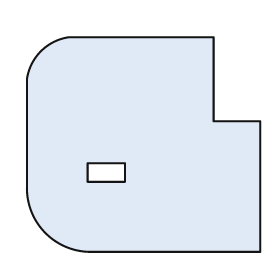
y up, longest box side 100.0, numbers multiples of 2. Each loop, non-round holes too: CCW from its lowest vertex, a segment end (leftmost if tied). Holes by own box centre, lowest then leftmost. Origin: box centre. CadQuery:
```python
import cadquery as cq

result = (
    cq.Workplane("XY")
    .moveTo(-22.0, -46.0)
    .lineTo(50.0, -46.0)
    .lineTo(50.0, 10.0)
    .lineTo(30.0, 10.0)
    .lineTo(30.0, 46.0)
    .lineTo(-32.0, 46.0)
    .threePointArc((-44.0, 40.0), (-50.0, 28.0))
    .lineTo(-50.0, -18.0)
    .threePointArc((-42.0, -38.0), (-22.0, -46.0))
    .close()
    .moveTo(-24.0, -16.0)
    .lineTo(-8.0, -16.0)
    .lineTo(-8.0, -8.0)
    .lineTo(-24.0, -8.0)
    .close()
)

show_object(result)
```